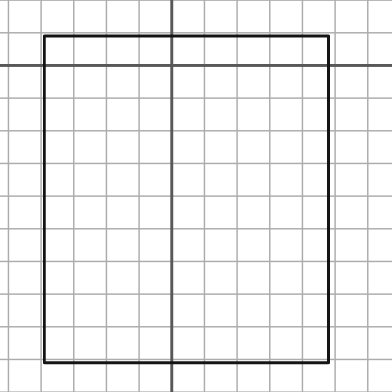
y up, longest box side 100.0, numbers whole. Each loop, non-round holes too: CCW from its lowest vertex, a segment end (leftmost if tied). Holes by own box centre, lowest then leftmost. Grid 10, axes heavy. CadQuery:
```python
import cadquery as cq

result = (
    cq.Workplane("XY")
    .moveTo(-39.0, -91.0)
    .lineTo(48.0, -91.0)
    .lineTo(48.0, 9.0)
    .lineTo(-39.0, 9.0)
    .close()
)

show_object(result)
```